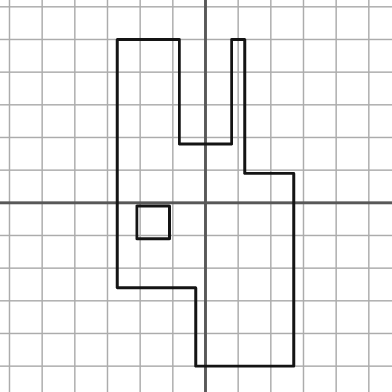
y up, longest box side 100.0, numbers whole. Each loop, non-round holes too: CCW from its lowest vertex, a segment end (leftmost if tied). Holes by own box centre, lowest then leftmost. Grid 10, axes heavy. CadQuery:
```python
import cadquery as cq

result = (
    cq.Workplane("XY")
    .moveTo(-3.0, -50.0)
    .lineTo(27.0, -50.0)
    .lineTo(27.0, 9.0)
    .lineTo(12.0, 9.0)
    .lineTo(12.0, 50.0)
    .lineTo(8.0, 50.0)
    .lineTo(8.0, 18.0)
    .lineTo(-8.0, 18.0)
    .lineTo(-8.0, 50.0)
    .lineTo(-27.0, 50.0)
    .lineTo(-27.0, -26.0)
    .lineTo(-3.0, -26.0)
    .close()
    .moveTo(-21.0, -11.0)
    .lineTo(-11.0, -11.0)
    .lineTo(-11.0, -1.0)
    .lineTo(-21.0, -1.0)
    .close()
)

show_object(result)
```